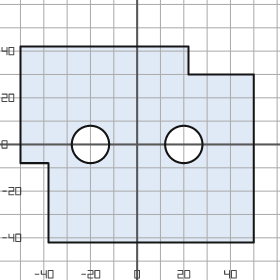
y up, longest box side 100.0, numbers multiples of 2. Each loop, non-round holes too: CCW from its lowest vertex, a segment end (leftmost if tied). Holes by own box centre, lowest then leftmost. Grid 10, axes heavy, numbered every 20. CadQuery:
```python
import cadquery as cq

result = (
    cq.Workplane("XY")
    .moveTo(-38.0, -42.0)
    .lineTo(50.0, -42.0)
    .lineTo(50.0, 30.0)
    .lineTo(22.0, 30.0)
    .lineTo(22.0, 42.0)
    .lineTo(-50.0, 42.0)
    .lineTo(-50.0, -8.0)
    .lineTo(-38.0, -8.0)
    .close()
    .moveTo(-20.0, 0.0)
    .circle(8.0)
    .moveTo(20.0, 0.0)
    .circle(8.0)
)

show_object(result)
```